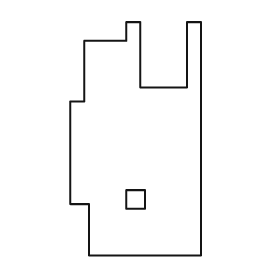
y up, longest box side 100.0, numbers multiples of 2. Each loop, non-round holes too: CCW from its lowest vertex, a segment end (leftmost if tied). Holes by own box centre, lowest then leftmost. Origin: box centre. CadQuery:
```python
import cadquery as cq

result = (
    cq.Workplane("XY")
    .moveTo(-20.0, -50.0)
    .lineTo(28.0, -50.0)
    .lineTo(28.0, 50.0)
    .lineTo(22.0, 50.0)
    .lineTo(22.0, 22.0)
    .lineTo(2.0, 22.0)
    .lineTo(2.0, 50.0)
    .lineTo(-4.0, 50.0)
    .lineTo(-4.0, 42.0)
    .lineTo(-22.0, 42.0)
    .lineTo(-22.0, 16.0)
    .lineTo(-28.0, 16.0)
    .lineTo(-28.0, -28.0)
    .lineTo(-20.0, -28.0)
    .close()
    .moveTo(-4.0, -30.0)
    .lineTo(4.0, -30.0)
    .lineTo(4.0, -22.0)
    .lineTo(-4.0, -22.0)
    .close()
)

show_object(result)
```